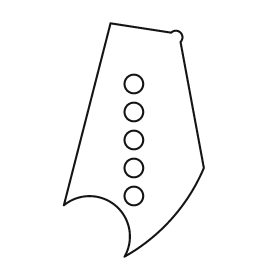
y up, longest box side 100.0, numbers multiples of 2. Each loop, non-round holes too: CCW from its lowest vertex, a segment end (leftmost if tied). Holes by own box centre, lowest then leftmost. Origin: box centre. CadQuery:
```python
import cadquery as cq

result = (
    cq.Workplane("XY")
    .moveTo(-4.0, -50.0)
    .threePointArc((16.0, -34.0), (30.0, -12.0))
    .lineTo(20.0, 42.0)
    .threePointArc((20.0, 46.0), (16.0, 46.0))
    .lineTo(-10.0, 50.0)
    .lineTo(-30.0, -28.0)
    .threePointArc((-8.0, -28.0), (-4.0, -50.0))
    .close()
    .moveTo(0.0, -24.0)
    .circle(4.0)
    .moveTo(0.0, -12.0)
    .circle(4.0)
    .moveTo(0.0, 0.0)
    .circle(4.0)
    .moveTo(0.0, 12.0)
    .circle(4.0)
    .moveTo(0.0, 24.0)
    .circle(4.0)
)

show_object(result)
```